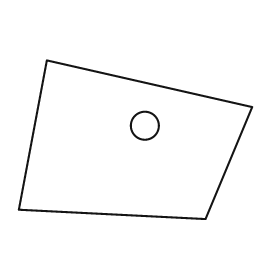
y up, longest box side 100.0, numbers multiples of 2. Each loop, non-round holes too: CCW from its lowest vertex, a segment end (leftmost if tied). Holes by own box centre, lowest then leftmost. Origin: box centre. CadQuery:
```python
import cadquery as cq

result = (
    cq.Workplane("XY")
    .moveTo(30.0, -34.0)
    .lineTo(50.0, 14.0)
    .lineTo(-38.0, 34.0)
    .lineTo(-50.0, -30.0)
    .close()
    .moveTo(4.0, 6.0)
    .circle(6.0)
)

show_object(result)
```